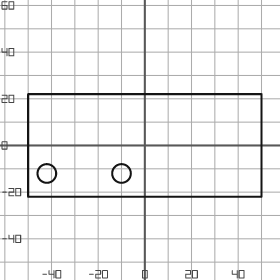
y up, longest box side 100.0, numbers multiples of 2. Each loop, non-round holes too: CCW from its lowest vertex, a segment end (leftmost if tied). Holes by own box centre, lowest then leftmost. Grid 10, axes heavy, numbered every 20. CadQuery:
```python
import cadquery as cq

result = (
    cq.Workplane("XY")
    .moveTo(-50.0, -22.0)
    .lineTo(50.0, -22.0)
    .lineTo(50.0, 22.0)
    .lineTo(-50.0, 22.0)
    .close()
    .moveTo(-42.0, -12.0)
    .circle(4.0)
    .moveTo(-10.0, -12.0)
    .circle(4.0)
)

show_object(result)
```